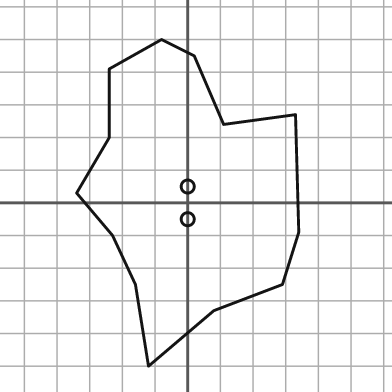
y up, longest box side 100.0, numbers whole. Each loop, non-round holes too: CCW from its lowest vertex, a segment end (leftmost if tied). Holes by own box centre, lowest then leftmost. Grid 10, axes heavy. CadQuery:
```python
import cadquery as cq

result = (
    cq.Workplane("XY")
    .moveTo(-12.0, -50.0)
    .lineTo(8.0, -33.0)
    .lineTo(29.0, -25.0)
    .lineTo(34.0, -9.0)
    .lineTo(33.0, 27.0)
    .lineTo(11.0, 24.0)
    .lineTo(2.0, 45.0)
    .lineTo(-8.0, 50.0)
    .lineTo(-24.0, 41.0)
    .lineTo(-24.0, 20.0)
    .lineTo(-34.0, 3.0)
    .lineTo(-23.0, -10.0)
    .lineTo(-16.0, -25.0)
    .close()
    .moveTo(0.0, -5.0)
    .circle(2.0)
    .moveTo(0.0, 5.0)
    .circle(2.0)
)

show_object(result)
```